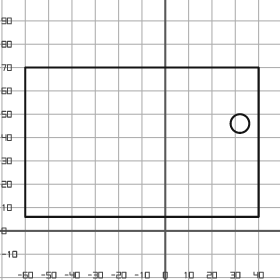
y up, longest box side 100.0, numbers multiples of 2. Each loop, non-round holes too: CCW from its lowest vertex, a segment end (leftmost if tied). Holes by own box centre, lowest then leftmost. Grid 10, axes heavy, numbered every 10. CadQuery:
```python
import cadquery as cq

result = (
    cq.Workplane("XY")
    .moveTo(-60.0, 6.0)
    .lineTo(40.0, 6.0)
    .lineTo(40.0, 70.0)
    .lineTo(-60.0, 70.0)
    .close()
    .moveTo(32.0, 46.0)
    .circle(4.0)
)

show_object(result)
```